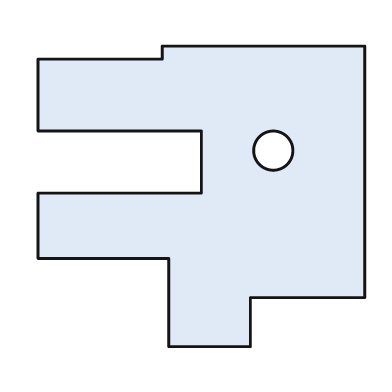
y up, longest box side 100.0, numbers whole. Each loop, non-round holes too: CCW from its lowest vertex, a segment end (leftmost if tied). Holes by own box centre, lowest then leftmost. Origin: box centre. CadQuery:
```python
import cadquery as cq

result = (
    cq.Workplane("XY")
    .moveTo(-10.0, -46.0)
    .lineTo(15.0, -46.0)
    .lineTo(15.0, -31.0)
    .lineTo(50.0, -31.0)
    .lineTo(50.0, 46.0)
    .lineTo(-12.0, 46.0)
    .lineTo(-12.0, 42.0)
    .lineTo(-50.0, 42.0)
    .lineTo(-50.0, 20.0)
    .lineTo(0.0, 20.0)
    .lineTo(0.0, 1.0)
    .lineTo(-50.0, 1.0)
    .lineTo(-50.0, -19.0)
    .lineTo(-10.0, -19.0)
    .close()
    .moveTo(22.0, 14.0)
    .circle(6.0)
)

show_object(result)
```